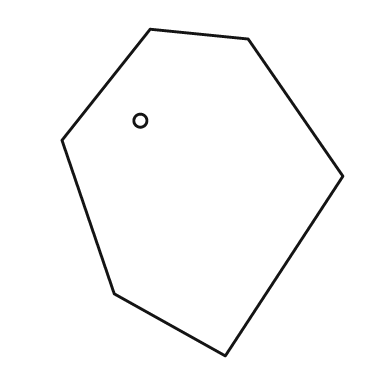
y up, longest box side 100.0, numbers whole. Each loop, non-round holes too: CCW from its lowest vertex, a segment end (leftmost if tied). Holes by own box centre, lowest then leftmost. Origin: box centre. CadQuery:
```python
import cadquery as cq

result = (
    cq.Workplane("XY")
    .moveTo(7.0, -50.0)
    .lineTo(43.0, 5.0)
    .lineTo(14.0, 47.0)
    .lineTo(-16.0, 50.0)
    .lineTo(-43.0, 16.0)
    .lineTo(-27.0, -31.0)
    .close()
    .moveTo(-19.0, 22.0)
    .circle(2.0)
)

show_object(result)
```